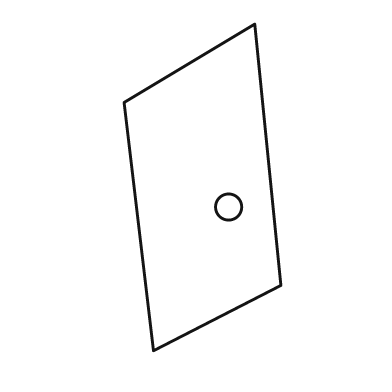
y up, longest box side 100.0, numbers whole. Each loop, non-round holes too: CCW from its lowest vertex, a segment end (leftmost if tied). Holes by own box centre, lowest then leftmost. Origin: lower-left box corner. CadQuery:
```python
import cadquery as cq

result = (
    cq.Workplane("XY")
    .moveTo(9.0, 0.0)
    .lineTo(48.0, 20.0)
    .lineTo(40.0, 100.0)
    .lineTo(0.0, 76.0)
    .close()
    .moveTo(32.0, 44.0)
    .circle(4.0)
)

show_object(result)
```